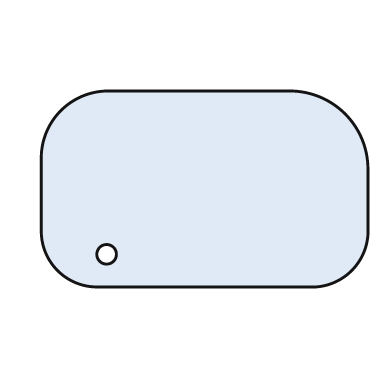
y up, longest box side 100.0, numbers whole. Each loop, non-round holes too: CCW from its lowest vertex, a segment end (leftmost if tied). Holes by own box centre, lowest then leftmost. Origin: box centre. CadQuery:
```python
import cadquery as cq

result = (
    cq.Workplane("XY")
    .moveTo(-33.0, -30.0)
    .lineTo(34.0, -30.0)
    .threePointArc((45.0, -25.0), (50.0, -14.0))
    .lineTo(50.0, 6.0)
    .threePointArc((43.0, 23.0), (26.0, 30.0))
    .lineTo(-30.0, 30.0)
    .threePointArc((-44.0, 24.0), (-50.0, 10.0))
    .lineTo(-50.0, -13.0)
    .threePointArc((-45.0, -25.0), (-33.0, -30.0))
    .close()
    .moveTo(-30.0, -20.0)
    .circle(3.0)
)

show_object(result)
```